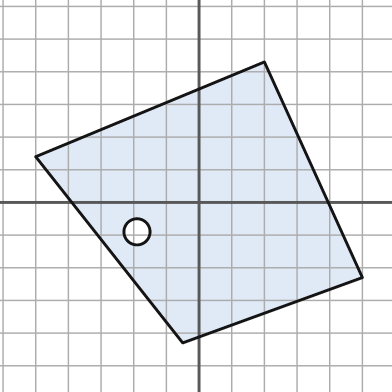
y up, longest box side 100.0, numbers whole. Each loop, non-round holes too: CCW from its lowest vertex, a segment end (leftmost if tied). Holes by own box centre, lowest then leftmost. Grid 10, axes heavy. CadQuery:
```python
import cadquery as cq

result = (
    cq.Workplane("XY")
    .moveTo(-5.0, -43.0)
    .lineTo(50.0, -23.0)
    .lineTo(20.0, 43.0)
    .lineTo(-50.0, 14.0)
    .close()
    .moveTo(-19.0, -9.0)
    .circle(4.0)
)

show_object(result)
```